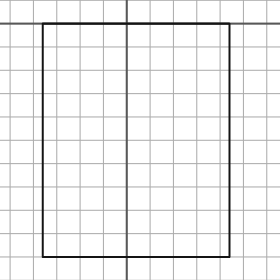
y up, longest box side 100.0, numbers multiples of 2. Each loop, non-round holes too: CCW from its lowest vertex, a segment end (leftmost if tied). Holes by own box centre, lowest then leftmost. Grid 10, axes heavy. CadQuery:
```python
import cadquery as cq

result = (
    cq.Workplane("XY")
    .moveTo(-36.0, -100.0)
    .lineTo(44.0, -100.0)
    .lineTo(44.0, 0.0)
    .lineTo(-36.0, 0.0)
    .close()
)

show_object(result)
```